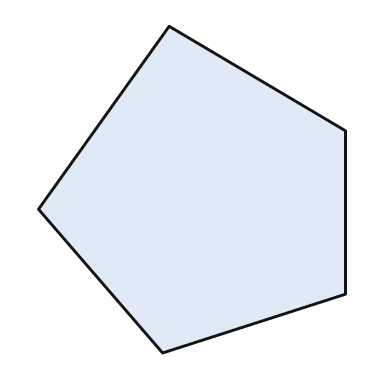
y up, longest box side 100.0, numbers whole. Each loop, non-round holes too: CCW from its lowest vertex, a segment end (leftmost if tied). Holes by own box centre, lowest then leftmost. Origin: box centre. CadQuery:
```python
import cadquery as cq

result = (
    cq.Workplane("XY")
    .moveTo(-9.0, -50.0)
    .lineTo(47.0, -32.0)
    .lineTo(47.0, 18.0)
    .lineTo(-7.0, 50.0)
    .lineTo(-47.0, -6.0)
    .close()
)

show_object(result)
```